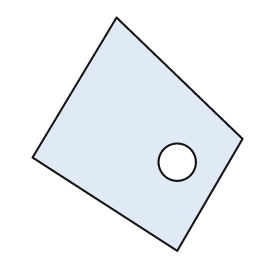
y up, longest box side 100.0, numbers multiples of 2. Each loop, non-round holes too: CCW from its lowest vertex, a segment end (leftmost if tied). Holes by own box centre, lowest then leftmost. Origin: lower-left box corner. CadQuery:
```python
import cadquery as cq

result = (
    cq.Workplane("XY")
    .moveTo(62.0, 0.0)
    .lineTo(90.0, 48.0)
    .lineTo(36.0, 100.0)
    .lineTo(0.0, 40.0)
    .close()
    .moveTo(62.0, 38.0)
    .circle(8.0)
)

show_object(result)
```